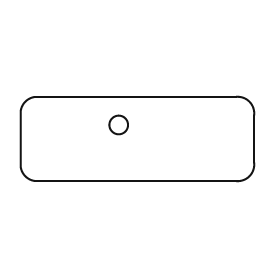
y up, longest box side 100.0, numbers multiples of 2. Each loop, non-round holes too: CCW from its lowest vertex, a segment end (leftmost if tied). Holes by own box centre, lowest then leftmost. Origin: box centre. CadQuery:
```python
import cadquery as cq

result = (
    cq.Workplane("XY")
    .moveTo(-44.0, -18.0)
    .lineTo(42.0, -18.0)
    .threePointArc((48.0, -16.0), (50.0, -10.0))
    .lineTo(50.0, 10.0)
    .threePointArc((48.0, 16.0), (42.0, 18.0))
    .lineTo(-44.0, 18.0)
    .threePointArc((-48.0, 16.0), (-50.0, 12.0))
    .lineTo(-50.0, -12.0)
    .threePointArc((-48.0, -16.0), (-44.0, -18.0))
    .close()
    .moveTo(-8.0, 6.0)
    .circle(4.0)
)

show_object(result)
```